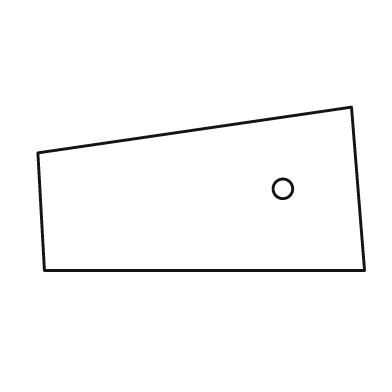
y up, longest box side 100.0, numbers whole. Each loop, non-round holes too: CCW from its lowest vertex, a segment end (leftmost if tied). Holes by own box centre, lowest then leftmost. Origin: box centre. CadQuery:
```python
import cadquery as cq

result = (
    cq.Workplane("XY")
    .moveTo(-48.0, -25.0)
    .lineTo(50.0, -25.0)
    .lineTo(46.0, 25.0)
    .lineTo(-50.0, 11.0)
    .close()
    .moveTo(25.0, 0.0)
    .circle(3.0)
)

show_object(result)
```